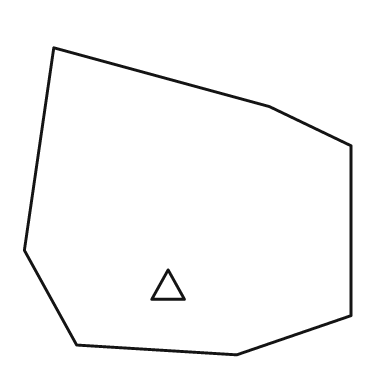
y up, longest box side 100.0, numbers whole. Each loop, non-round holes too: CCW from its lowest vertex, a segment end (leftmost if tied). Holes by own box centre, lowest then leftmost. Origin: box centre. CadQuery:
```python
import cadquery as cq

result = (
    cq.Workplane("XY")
    .moveTo(15.0, -47.0)
    .lineTo(50.0, -35.0)
    .lineTo(50.0, 17.0)
    .lineTo(25.0, 29.0)
    .lineTo(-41.0, 47.0)
    .lineTo(-50.0, -15.0)
    .lineTo(-34.0, -44.0)
    .close()
    .moveTo(-11.0, -30.0)
    .lineTo(-1.0, -30.0)
    .lineTo(-6.0, -21.0)
    .close()
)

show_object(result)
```